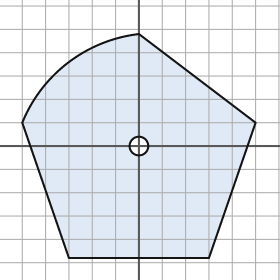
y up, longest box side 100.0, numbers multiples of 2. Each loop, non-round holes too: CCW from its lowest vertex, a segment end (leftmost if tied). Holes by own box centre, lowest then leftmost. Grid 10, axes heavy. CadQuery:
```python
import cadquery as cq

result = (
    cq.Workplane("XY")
    .moveTo(-30.0, -48.0)
    .lineTo(30.0, -48.0)
    .lineTo(50.0, 10.0)
    .lineTo(0.0, 48.0)
    .threePointArc((-30.0, 36.0), (-50.0, 10.0))
    .close()
    .moveTo(0.0, 0.0)
    .circle(4.0)
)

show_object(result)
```